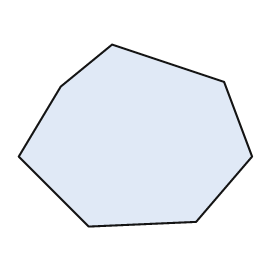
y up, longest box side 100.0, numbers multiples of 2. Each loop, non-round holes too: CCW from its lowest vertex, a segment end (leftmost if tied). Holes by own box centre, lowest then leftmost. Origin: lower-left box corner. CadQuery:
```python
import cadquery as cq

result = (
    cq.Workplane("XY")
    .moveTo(30.0, 0.0)
    .lineTo(76.0, 2.0)
    .lineTo(100.0, 30.0)
    .lineTo(88.0, 62.0)
    .lineTo(40.0, 78.0)
    .lineTo(18.0, 60.0)
    .lineTo(0.0, 30.0)
    .close()
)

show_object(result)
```